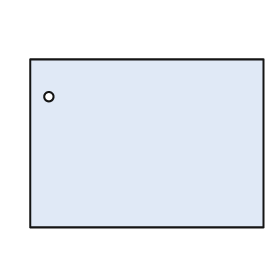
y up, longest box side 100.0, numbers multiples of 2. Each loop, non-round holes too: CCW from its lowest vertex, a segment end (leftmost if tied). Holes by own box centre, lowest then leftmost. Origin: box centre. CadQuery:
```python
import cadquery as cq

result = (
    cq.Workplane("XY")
    .moveTo(-50.0, -36.0)
    .lineTo(50.0, -36.0)
    .lineTo(50.0, 36.0)
    .lineTo(-50.0, 36.0)
    .close()
    .moveTo(-42.0, 20.0)
    .circle(2.0)
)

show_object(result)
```